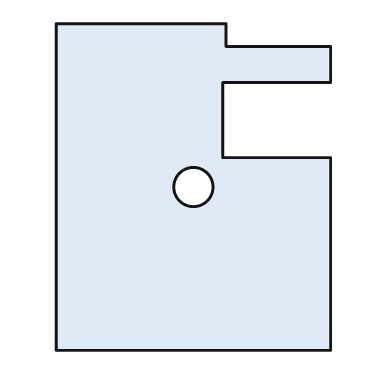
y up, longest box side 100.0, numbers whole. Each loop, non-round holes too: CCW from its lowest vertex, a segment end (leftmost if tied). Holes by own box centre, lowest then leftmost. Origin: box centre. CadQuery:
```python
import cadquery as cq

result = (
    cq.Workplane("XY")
    .moveTo(-42.0, -50.0)
    .lineTo(42.0, -50.0)
    .lineTo(42.0, 9.0)
    .lineTo(9.0, 9.0)
    .lineTo(9.0, 32.0)
    .lineTo(42.0, 32.0)
    .lineTo(42.0, 43.0)
    .lineTo(10.0, 43.0)
    .lineTo(10.0, 50.0)
    .lineTo(-42.0, 50.0)
    .close()
    .moveTo(0.0, 0.0)
    .circle(6.0)
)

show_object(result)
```